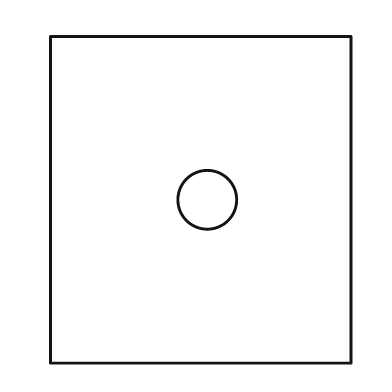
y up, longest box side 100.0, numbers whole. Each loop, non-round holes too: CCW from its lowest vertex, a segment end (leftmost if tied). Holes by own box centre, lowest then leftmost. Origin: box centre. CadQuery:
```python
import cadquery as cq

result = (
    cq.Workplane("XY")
    .moveTo(-46.0, -50.0)
    .lineTo(46.0, -50.0)
    .lineTo(46.0, 50.0)
    .lineTo(-46.0, 50.0)
    .close()
    .moveTo(2.0, 0.0)
    .circle(9.0)
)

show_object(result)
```